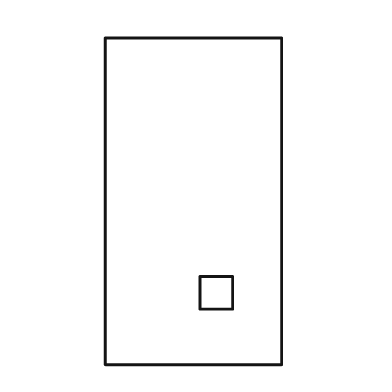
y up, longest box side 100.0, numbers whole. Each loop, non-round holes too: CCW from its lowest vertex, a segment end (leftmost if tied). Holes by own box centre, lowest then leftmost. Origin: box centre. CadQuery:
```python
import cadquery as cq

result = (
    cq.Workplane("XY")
    .moveTo(-27.0, -50.0)
    .lineTo(27.0, -50.0)
    .lineTo(27.0, 50.0)
    .lineTo(-27.0, 50.0)
    .close()
    .moveTo(2.0, -33.0)
    .lineTo(12.0, -33.0)
    .lineTo(12.0, -23.0)
    .lineTo(2.0, -23.0)
    .close()
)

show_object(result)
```